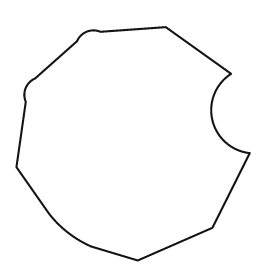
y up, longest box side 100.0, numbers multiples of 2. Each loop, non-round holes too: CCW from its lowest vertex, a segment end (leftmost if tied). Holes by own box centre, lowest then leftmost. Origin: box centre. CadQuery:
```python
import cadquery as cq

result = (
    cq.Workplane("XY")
    .moveTo(2.0, -50.0)
    .lineTo(34.0, -36.0)
    .lineTo(50.0, -4.0)
    .threePointArc((34.0, 10.0), (42.0, 30.0))
    .lineTo(14.0, 50.0)
    .lineTo(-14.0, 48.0)
    .threePointArc((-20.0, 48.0), (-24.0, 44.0))
    .lineTo(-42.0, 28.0)
    .threePointArc((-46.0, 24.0), (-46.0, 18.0))
    .lineTo(-50.0, -10.0)
    .lineTo(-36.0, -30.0)
    .threePointArc((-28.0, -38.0), (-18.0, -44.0))
    .close()
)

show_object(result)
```